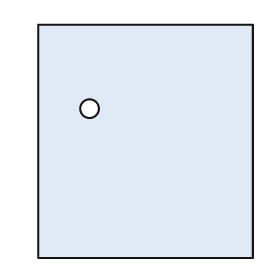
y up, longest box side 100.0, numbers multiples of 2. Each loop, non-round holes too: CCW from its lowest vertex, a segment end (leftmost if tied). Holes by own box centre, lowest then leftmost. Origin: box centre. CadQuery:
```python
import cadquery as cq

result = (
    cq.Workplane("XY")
    .moveTo(-46.0, -50.0)
    .lineTo(46.0, -50.0)
    .lineTo(46.0, 50.0)
    .lineTo(-46.0, 50.0)
    .close()
    .moveTo(-24.0, 14.0)
    .circle(4.0)
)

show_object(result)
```